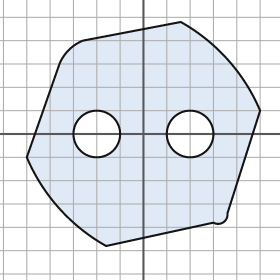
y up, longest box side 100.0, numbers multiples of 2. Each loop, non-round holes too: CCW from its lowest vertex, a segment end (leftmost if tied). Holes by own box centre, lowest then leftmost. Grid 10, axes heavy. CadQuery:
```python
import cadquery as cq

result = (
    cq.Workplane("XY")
    .moveTo(-16.0, -48.0)
    .lineTo(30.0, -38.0)
    .threePointArc((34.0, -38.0), (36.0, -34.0))
    .lineTo(50.0, 10.0)
    .threePointArc((36.0, 32.0), (16.0, 48.0))
    .lineTo(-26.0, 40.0)
    .threePointArc((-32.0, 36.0), (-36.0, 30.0))
    .lineTo(-50.0, -10.0)
    .threePointArc((-36.0, -32.0), (-16.0, -48.0))
    .close()
    .moveTo(-20.0, 0.0)
    .circle(10.0)
    .moveTo(20.0, 0.0)
    .circle(10.0)
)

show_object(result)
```